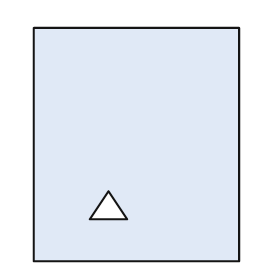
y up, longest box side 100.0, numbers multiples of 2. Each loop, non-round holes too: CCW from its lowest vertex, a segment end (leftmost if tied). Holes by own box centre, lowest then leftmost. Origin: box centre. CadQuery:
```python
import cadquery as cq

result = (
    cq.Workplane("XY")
    .moveTo(-44.0, -50.0)
    .lineTo(44.0, -50.0)
    .lineTo(44.0, 50.0)
    .lineTo(-44.0, 50.0)
    .close()
    .moveTo(-20.0, -32.0)
    .lineTo(-4.0, -32.0)
    .lineTo(-12.0, -20.0)
    .close()
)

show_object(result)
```